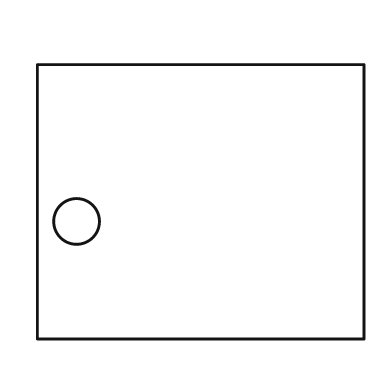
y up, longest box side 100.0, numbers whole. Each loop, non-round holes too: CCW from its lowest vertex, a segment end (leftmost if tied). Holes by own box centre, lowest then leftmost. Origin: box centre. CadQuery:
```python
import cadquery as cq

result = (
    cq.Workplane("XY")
    .moveTo(-50.0, -42.0)
    .lineTo(50.0, -42.0)
    .lineTo(50.0, 42.0)
    .lineTo(-50.0, 42.0)
    .close()
    .moveTo(-38.0, -6.0)
    .circle(7.0)
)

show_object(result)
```